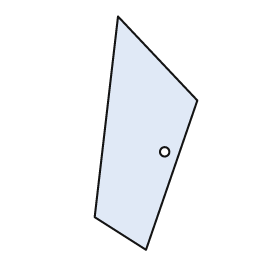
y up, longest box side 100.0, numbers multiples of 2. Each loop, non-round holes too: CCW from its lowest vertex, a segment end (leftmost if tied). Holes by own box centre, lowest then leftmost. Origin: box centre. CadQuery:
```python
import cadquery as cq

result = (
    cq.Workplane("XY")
    .moveTo(0.0, -50.0)
    .lineTo(22.0, 14.0)
    .lineTo(-12.0, 50.0)
    .lineTo(-22.0, -36.0)
    .close()
    .moveTo(8.0, -8.0)
    .circle(2.0)
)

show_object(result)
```